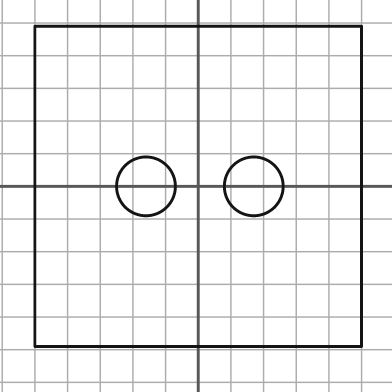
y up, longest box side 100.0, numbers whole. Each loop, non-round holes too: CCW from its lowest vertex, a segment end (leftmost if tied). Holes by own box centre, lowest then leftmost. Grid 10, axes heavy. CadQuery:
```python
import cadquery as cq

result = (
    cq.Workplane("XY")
    .moveTo(-50.0, -49.0)
    .lineTo(50.0, -49.0)
    .lineTo(50.0, 49.0)
    .lineTo(-50.0, 49.0)
    .close()
    .moveTo(-16.0, 0.0)
    .circle(9.0)
    .moveTo(17.0, 0.0)
    .circle(9.0)
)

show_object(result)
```